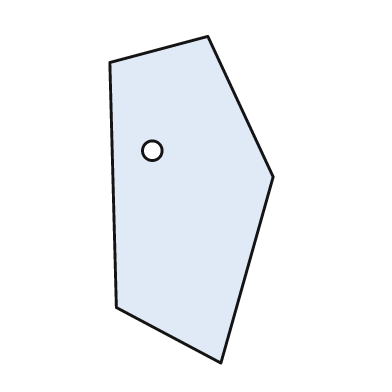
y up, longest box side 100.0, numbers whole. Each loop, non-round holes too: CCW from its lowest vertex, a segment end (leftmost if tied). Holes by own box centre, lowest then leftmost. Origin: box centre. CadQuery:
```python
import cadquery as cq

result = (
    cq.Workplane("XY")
    .moveTo(9.0, -50.0)
    .lineTo(25.0, 7.0)
    .lineTo(5.0, 50.0)
    .lineTo(-25.0, 42.0)
    .lineTo(-23.0, -33.0)
    .close()
    .moveTo(-12.0, 15.0)
    .circle(3.0)
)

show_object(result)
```